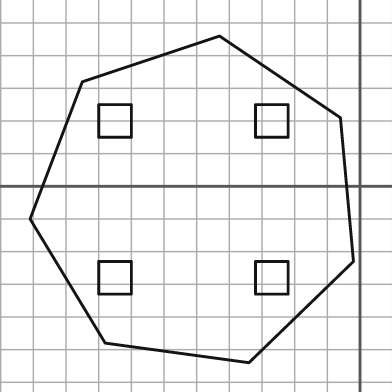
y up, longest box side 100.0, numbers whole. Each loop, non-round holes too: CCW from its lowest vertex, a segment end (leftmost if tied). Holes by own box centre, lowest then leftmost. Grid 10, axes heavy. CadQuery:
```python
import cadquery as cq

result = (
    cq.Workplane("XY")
    .moveTo(-34.0, -54.0)
    .lineTo(-2.0, -23.0)
    .lineTo(-6.0, 21.0)
    .lineTo(-43.0, 46.0)
    .lineTo(-85.0, 32.0)
    .lineTo(-101.0, -10.0)
    .lineTo(-78.0, -48.0)
    .close()
    .moveTo(-80.0, -33.0)
    .lineTo(-70.0, -33.0)
    .lineTo(-70.0, -23.0)
    .lineTo(-80.0, -23.0)
    .close()
    .moveTo(-32.0, -33.0)
    .lineTo(-22.0, -33.0)
    .lineTo(-22.0, -23.0)
    .lineTo(-32.0, -23.0)
    .close()
    .moveTo(-80.0, 15.0)
    .lineTo(-70.0, 15.0)
    .lineTo(-70.0, 25.0)
    .lineTo(-80.0, 25.0)
    .close()
    .moveTo(-32.0, 15.0)
    .lineTo(-22.0, 15.0)
    .lineTo(-22.0, 25.0)
    .lineTo(-32.0, 25.0)
    .close()
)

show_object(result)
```